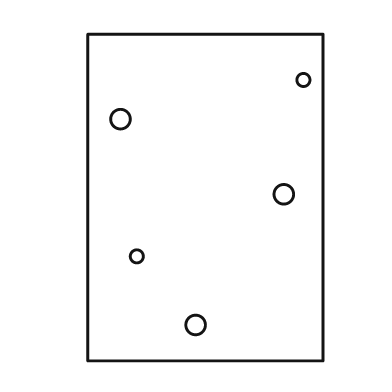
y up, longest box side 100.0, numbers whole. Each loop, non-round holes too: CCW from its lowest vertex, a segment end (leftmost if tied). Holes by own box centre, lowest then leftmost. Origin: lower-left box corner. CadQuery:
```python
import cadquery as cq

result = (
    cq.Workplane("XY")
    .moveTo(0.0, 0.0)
    .lineTo(72.0, 0.0)
    .lineTo(72.0, 100.0)
    .lineTo(0.0, 100.0)
    .close()
    .moveTo(33.0, 11.0)
    .circle(3.0)
    .moveTo(15.0, 32.0)
    .circle(2.0)
    .moveTo(60.0, 51.0)
    .circle(3.0)
    .moveTo(10.0, 74.0)
    .circle(3.0)
    .moveTo(66.0, 86.0)
    .circle(2.0)
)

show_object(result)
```